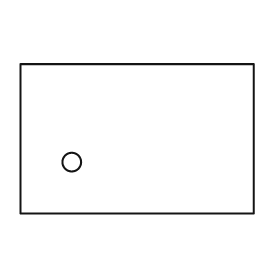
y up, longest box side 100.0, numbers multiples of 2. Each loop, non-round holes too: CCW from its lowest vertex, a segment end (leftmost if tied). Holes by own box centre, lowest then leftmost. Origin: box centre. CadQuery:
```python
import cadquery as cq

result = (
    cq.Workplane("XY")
    .moveTo(-50.0, -32.0)
    .lineTo(50.0, -32.0)
    .lineTo(50.0, 32.0)
    .lineTo(-50.0, 32.0)
    .close()
    .moveTo(-28.0, -10.0)
    .circle(4.0)
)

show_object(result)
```